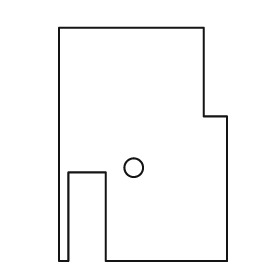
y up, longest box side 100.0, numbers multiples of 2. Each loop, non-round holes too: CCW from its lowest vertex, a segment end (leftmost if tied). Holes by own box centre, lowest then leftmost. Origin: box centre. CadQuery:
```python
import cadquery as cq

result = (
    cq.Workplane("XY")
    .moveTo(-36.0, -50.0)
    .lineTo(-32.0, -50.0)
    .lineTo(-32.0, -12.0)
    .lineTo(-16.0, -12.0)
    .lineTo(-16.0, -50.0)
    .lineTo(36.0, -50.0)
    .lineTo(36.0, 12.0)
    .lineTo(26.0, 12.0)
    .lineTo(26.0, 50.0)
    .lineTo(-36.0, 50.0)
    .close()
    .moveTo(-4.0, -10.0)
    .circle(4.0)
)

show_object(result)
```